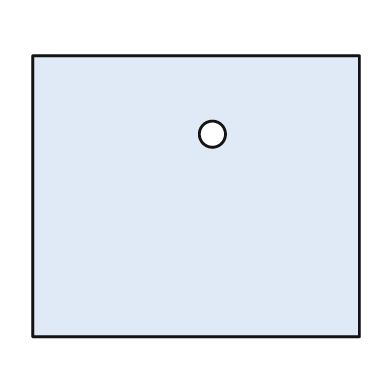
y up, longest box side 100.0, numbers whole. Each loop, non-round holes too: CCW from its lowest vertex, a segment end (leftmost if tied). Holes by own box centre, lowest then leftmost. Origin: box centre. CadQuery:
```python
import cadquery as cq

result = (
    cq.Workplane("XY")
    .moveTo(-50.0, -43.0)
    .lineTo(50.0, -43.0)
    .lineTo(50.0, 43.0)
    .lineTo(-50.0, 43.0)
    .close()
    .moveTo(5.0, 19.0)
    .circle(4.0)
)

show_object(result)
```